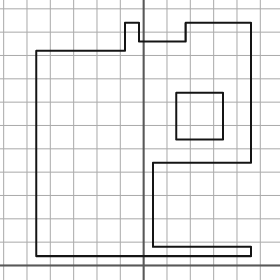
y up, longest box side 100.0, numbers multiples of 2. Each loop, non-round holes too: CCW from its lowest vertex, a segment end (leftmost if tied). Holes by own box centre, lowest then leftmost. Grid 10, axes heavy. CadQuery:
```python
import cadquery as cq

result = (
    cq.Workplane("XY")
    .moveTo(-46.0, 4.0)
    .lineTo(46.0, 4.0)
    .lineTo(46.0, 8.0)
    .lineTo(4.0, 8.0)
    .lineTo(4.0, 44.0)
    .lineTo(46.0, 44.0)
    .lineTo(46.0, 104.0)
    .lineTo(18.0, 104.0)
    .lineTo(18.0, 96.0)
    .lineTo(-2.0, 96.0)
    .lineTo(-2.0, 104.0)
    .lineTo(-8.0, 104.0)
    .lineTo(-8.0, 92.0)
    .lineTo(-46.0, 92.0)
    .close()
    .moveTo(14.0, 54.0)
    .lineTo(34.0, 54.0)
    .lineTo(34.0, 74.0)
    .lineTo(14.0, 74.0)
    .close()
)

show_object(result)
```